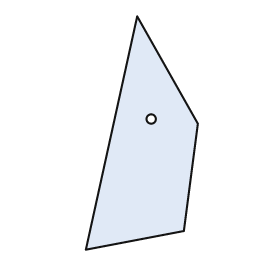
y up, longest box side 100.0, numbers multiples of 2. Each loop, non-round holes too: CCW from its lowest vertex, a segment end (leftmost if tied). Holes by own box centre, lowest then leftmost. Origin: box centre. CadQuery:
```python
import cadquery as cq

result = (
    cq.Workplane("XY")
    .moveTo(-24.0, -50.0)
    .lineTo(18.0, -42.0)
    .lineTo(24.0, 4.0)
    .lineTo(-2.0, 50.0)
    .close()
    .moveTo(4.0, 6.0)
    .circle(2.0)
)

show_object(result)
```